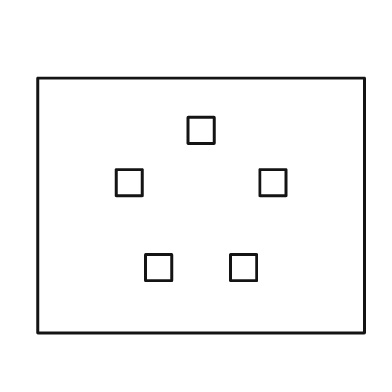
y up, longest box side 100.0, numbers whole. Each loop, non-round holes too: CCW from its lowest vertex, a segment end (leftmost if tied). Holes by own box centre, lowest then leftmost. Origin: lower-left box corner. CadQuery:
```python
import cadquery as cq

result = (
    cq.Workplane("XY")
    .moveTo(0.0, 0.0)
    .lineTo(100.0, 0.0)
    .lineTo(100.0, 78.0)
    .lineTo(0.0, 78.0)
    .close()
    .moveTo(33.0, 16.0)
    .lineTo(41.0, 16.0)
    .lineTo(41.0, 24.0)
    .lineTo(33.0, 24.0)
    .close()
    .moveTo(59.0, 16.0)
    .lineTo(67.0, 16.0)
    .lineTo(67.0, 24.0)
    .lineTo(59.0, 24.0)
    .close()
    .moveTo(24.0, 42.0)
    .lineTo(32.0, 42.0)
    .lineTo(32.0, 50.0)
    .lineTo(24.0, 50.0)
    .close()
    .moveTo(68.0, 42.0)
    .lineTo(76.0, 42.0)
    .lineTo(76.0, 50.0)
    .lineTo(68.0, 50.0)
    .close()
    .moveTo(46.0, 58.0)
    .lineTo(54.0, 58.0)
    .lineTo(54.0, 66.0)
    .lineTo(46.0, 66.0)
    .close()
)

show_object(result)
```